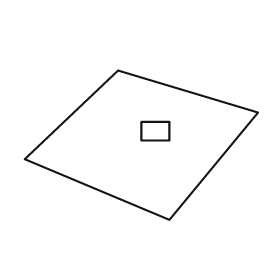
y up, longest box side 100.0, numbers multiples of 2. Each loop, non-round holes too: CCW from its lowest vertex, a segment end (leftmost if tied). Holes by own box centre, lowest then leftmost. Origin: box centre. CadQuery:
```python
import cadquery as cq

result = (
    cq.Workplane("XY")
    .moveTo(12.0, -32.0)
    .lineTo(50.0, 14.0)
    .lineTo(-10.0, 32.0)
    .lineTo(-50.0, -6.0)
    .close()
    .moveTo(0.0, 2.0)
    .lineTo(12.0, 2.0)
    .lineTo(12.0, 10.0)
    .lineTo(0.0, 10.0)
    .close()
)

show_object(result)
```